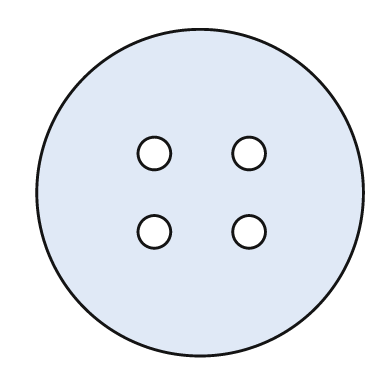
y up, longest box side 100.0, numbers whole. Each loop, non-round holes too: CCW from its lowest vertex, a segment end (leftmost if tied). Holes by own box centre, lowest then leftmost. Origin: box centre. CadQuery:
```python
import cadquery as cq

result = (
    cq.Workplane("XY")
    .moveTo(0.0, 0.0)
    .circle(50.0)
    .moveTo(-14.0, -12.0)
    .circle(5.0)
    .moveTo(15.0, -12.0)
    .circle(5.0)
    .moveTo(-14.0, 12.0)
    .circle(5.0)
    .moveTo(15.0, 12.0)
    .circle(5.0)
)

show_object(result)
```